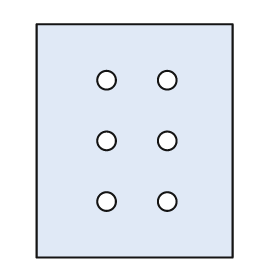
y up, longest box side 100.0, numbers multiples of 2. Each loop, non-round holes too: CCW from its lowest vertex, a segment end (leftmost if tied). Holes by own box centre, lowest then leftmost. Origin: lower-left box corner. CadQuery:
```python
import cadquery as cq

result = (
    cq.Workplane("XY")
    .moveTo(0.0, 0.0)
    .lineTo(84.0, 0.0)
    .lineTo(84.0, 100.0)
    .lineTo(0.0, 100.0)
    .close()
    .moveTo(30.0, 24.0)
    .circle(4.0)
    .moveTo(56.0, 24.0)
    .circle(4.0)
    .moveTo(30.0, 50.0)
    .circle(4.0)
    .moveTo(56.0, 50.0)
    .circle(4.0)
    .moveTo(30.0, 76.0)
    .circle(4.0)
    .moveTo(56.0, 76.0)
    .circle(4.0)
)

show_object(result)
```